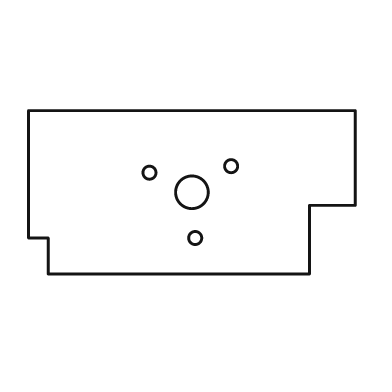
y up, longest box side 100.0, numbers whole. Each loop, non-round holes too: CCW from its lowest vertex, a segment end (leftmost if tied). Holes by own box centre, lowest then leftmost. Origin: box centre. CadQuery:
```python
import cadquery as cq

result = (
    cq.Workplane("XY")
    .moveTo(-44.0, -25.0)
    .lineTo(36.0, -25.0)
    .lineTo(36.0, -4.0)
    .lineTo(50.0, -4.0)
    .lineTo(50.0, 25.0)
    .lineTo(-50.0, 25.0)
    .lineTo(-50.0, -14.0)
    .lineTo(-44.0, -14.0)
    .close()
    .moveTo(1.0, -14.0)
    .circle(2.0)
    .moveTo(0.0, 0.0)
    .circle(5.0)
    .moveTo(-13.0, 6.0)
    .circle(2.0)
    .moveTo(12.0, 8.0)
    .circle(2.0)
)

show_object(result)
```